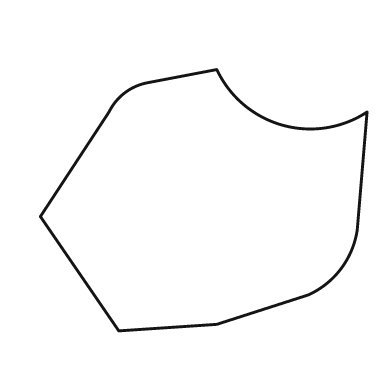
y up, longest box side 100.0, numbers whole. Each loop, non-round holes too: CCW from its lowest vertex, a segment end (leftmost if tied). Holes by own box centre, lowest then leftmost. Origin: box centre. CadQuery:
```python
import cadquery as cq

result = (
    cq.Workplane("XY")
    .moveTo(-26.0, -40.0)
    .lineTo(4.0, -38.0)
    .lineTo(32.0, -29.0)
    .threePointArc((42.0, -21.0), (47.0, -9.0))
    .lineTo(50.0, 27.0)
    .threePointArc((24.0, 23.0), (4.0, 40.0))
    .lineTo(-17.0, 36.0)
    .threePointArc((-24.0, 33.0), (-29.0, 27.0))
    .lineTo(-50.0, -5.0)
    .close()
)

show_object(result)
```